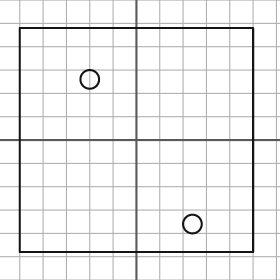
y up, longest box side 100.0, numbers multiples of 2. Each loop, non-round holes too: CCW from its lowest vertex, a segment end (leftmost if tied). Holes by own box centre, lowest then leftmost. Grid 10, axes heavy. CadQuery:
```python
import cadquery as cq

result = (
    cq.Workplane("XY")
    .moveTo(-50.0, -48.0)
    .lineTo(50.0, -48.0)
    .lineTo(50.0, 48.0)
    .lineTo(-50.0, 48.0)
    .close()
    .moveTo(24.0, -36.0)
    .circle(4.0)
    .moveTo(-20.0, 26.0)
    .circle(4.0)
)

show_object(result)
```